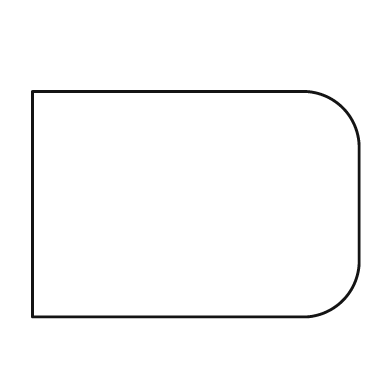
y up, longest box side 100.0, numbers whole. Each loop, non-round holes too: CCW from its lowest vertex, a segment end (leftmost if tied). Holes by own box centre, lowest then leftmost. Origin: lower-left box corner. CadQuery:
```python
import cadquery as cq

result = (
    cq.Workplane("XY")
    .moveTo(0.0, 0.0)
    .lineTo(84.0, 0.0)
    .threePointArc((95.0, 5.0), (100.0, 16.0))
    .lineTo(100.0, 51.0)
    .threePointArc((95.0, 64.0), (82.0, 69.0))
    .lineTo(0.0, 69.0)
    .close()
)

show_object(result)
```